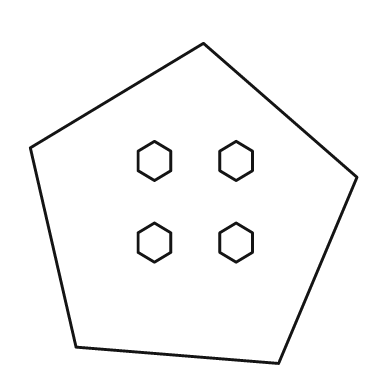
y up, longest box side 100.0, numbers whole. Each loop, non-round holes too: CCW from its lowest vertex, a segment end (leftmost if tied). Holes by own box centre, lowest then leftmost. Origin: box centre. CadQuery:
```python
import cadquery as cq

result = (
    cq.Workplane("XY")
    .moveTo(26.0, -49.0)
    .lineTo(50.0, 8.0)
    .lineTo(3.0, 49.0)
    .lineTo(-50.0, 17.0)
    .lineTo(-36.0, -44.0)
    .close()
    .moveTo(-12.0, -18.0)
    .lineTo(-7.0, -15.0)
    .lineTo(-7.0, -9.0)
    .lineTo(-12.0, -6.0)
    .lineTo(-17.0, -9.0)
    .lineTo(-17.0, -15.0)
    .close()
    .moveTo(13.0, -18.0)
    .lineTo(18.0, -15.0)
    .lineTo(18.0, -9.0)
    .lineTo(13.0, -6.0)
    .lineTo(8.0, -9.0)
    .lineTo(8.0, -15.0)
    .close()
    .moveTo(-12.0, 7.0)
    .lineTo(-7.0, 10.0)
    .lineTo(-7.0, 16.0)
    .lineTo(-12.0, 19.0)
    .lineTo(-17.0, 16.0)
    .lineTo(-17.0, 10.0)
    .close()
    .moveTo(13.0, 7.0)
    .lineTo(18.0, 10.0)
    .lineTo(18.0, 16.0)
    .lineTo(13.0, 19.0)
    .lineTo(8.0, 16.0)
    .lineTo(8.0, 10.0)
    .close()
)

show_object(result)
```